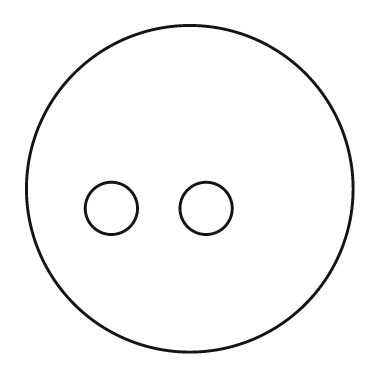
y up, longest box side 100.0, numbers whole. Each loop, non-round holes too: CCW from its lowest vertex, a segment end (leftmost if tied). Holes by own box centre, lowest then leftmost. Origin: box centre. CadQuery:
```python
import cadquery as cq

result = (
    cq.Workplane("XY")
    .moveTo(0.0, 0.0)
    .circle(50.0)
    .moveTo(-24.0, -6.0)
    .circle(8.0)
    .moveTo(5.0, -6.0)
    .circle(8.0)
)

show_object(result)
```